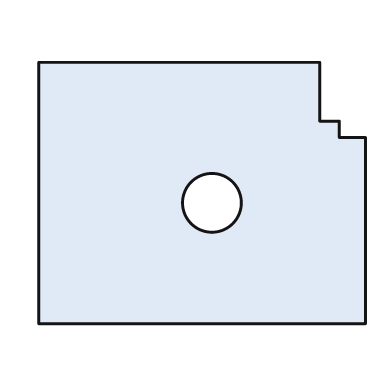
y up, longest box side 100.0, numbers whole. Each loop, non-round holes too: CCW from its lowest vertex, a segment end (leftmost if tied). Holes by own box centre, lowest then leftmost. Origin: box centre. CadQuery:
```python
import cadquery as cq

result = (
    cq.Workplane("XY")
    .moveTo(-50.0, -40.0)
    .lineTo(50.0, -40.0)
    .lineTo(50.0, 17.0)
    .lineTo(42.0, 17.0)
    .lineTo(42.0, 22.0)
    .lineTo(36.0, 22.0)
    .lineTo(36.0, 40.0)
    .lineTo(-50.0, 40.0)
    .close()
    .moveTo(3.0, -3.0)
    .circle(9.0)
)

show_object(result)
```